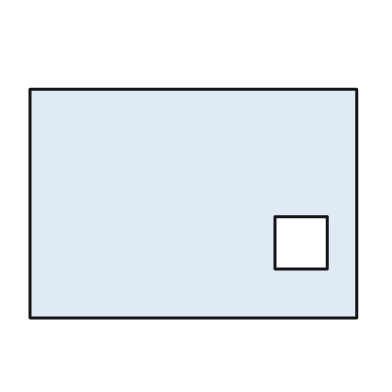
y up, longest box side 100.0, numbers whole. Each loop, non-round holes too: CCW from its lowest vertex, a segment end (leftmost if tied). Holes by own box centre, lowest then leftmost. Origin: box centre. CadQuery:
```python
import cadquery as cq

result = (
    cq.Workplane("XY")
    .moveTo(-50.0, -35.0)
    .lineTo(50.0, -35.0)
    .lineTo(50.0, 35.0)
    .lineTo(-50.0, 35.0)
    .close()
    .moveTo(25.0, -20.0)
    .lineTo(41.0, -20.0)
    .lineTo(41.0, -4.0)
    .lineTo(25.0, -4.0)
    .close()
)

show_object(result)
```